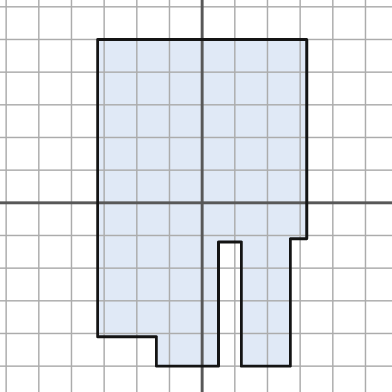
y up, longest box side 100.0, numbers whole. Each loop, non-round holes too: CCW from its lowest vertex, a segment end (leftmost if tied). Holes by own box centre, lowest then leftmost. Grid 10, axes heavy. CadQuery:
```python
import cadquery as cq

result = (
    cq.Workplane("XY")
    .moveTo(-14.0, -50.0)
    .lineTo(5.0, -50.0)
    .lineTo(5.0, -12.0)
    .lineTo(12.0, -12.0)
    .lineTo(12.0, -50.0)
    .lineTo(27.0, -50.0)
    .lineTo(27.0, -11.0)
    .lineTo(32.0, -11.0)
    .lineTo(32.0, 50.0)
    .lineTo(-32.0, 50.0)
    .lineTo(-32.0, -41.0)
    .lineTo(-14.0, -41.0)
    .close()
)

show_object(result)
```